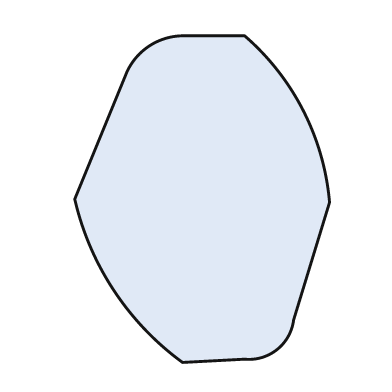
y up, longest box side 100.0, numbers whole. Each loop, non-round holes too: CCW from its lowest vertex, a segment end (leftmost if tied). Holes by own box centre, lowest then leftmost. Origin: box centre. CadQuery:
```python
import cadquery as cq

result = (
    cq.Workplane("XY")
    .moveTo(-6.0, -50.0)
    .lineTo(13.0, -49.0)
    .threePointArc((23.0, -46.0), (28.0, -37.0))
    .lineTo(39.0, -1.0)
    .threePointArc((31.0, 27.0), (13.0, 50.0))
    .lineTo(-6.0, 50.0)
    .threePointArc((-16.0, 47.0), (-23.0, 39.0))
    .lineTo(-39.0, 0.0)
    .threePointArc((-27.0, -28.0), (-6.0, -50.0))
    .close()
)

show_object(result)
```